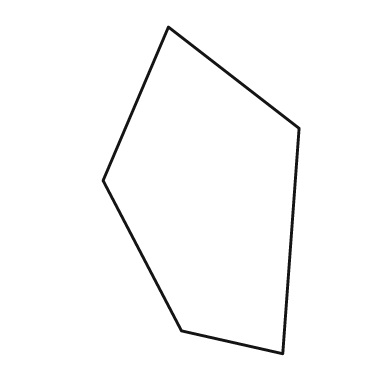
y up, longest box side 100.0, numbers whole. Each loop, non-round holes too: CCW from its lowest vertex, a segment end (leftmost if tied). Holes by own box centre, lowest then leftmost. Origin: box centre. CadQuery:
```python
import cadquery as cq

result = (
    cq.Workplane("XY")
    .moveTo(25.0, -50.0)
    .lineTo(30.0, 19.0)
    .lineTo(-10.0, 50.0)
    .lineTo(-30.0, 3.0)
    .lineTo(-6.0, -43.0)
    .close()
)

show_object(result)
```